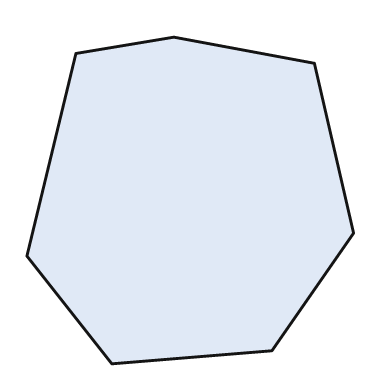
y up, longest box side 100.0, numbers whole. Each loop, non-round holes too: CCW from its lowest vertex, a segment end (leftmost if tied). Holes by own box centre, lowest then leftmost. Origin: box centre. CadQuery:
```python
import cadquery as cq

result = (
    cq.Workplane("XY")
    .moveTo(-24.0, -50.0)
    .lineTo(25.0, -46.0)
    .lineTo(50.0, -10.0)
    .lineTo(38.0, 42.0)
    .lineTo(-5.0, 50.0)
    .lineTo(-35.0, 45.0)
    .lineTo(-50.0, -17.0)
    .close()
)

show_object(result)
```